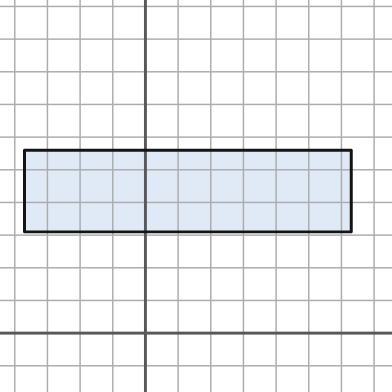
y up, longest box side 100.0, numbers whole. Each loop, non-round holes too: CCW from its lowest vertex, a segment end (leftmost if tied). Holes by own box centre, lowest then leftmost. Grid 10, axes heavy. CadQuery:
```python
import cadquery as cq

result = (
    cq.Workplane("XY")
    .moveTo(-37.0, 31.0)
    .lineTo(63.0, 31.0)
    .lineTo(63.0, 56.0)
    .lineTo(-37.0, 56.0)
    .close()
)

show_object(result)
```